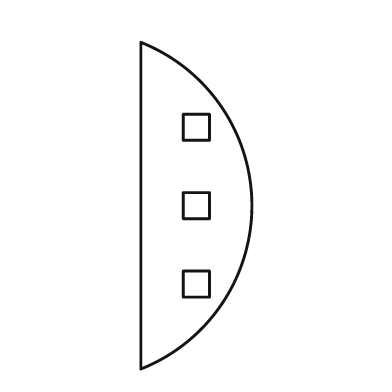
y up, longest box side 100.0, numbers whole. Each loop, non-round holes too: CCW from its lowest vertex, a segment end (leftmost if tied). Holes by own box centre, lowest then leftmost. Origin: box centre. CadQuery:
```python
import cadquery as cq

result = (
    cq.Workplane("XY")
    .moveTo(-17.0, -50.0)
    .threePointArc((17.0, 0.0), (-17.0, 50.0))
    .close()
    .moveTo(-4.0, -28.0)
    .lineTo(4.0, -28.0)
    .lineTo(4.0, -20.0)
    .lineTo(-4.0, -20.0)
    .close()
    .moveTo(-4.0, -4.0)
    .lineTo(4.0, -4.0)
    .lineTo(4.0, 4.0)
    .lineTo(-4.0, 4.0)
    .close()
    .moveTo(-4.0, 20.0)
    .lineTo(4.0, 20.0)
    .lineTo(4.0, 28.0)
    .lineTo(-4.0, 28.0)
    .close()
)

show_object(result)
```